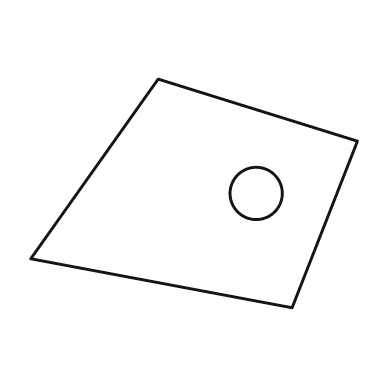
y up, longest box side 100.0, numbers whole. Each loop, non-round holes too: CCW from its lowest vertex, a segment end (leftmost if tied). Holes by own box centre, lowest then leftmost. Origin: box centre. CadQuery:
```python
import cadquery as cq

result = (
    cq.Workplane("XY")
    .moveTo(30.0, -35.0)
    .lineTo(50.0, 16.0)
    .lineTo(-11.0, 35.0)
    .lineTo(-50.0, -20.0)
    .close()
    .moveTo(19.0, 0.0)
    .circle(8.0)
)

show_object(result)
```